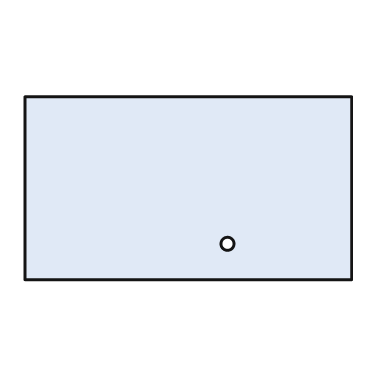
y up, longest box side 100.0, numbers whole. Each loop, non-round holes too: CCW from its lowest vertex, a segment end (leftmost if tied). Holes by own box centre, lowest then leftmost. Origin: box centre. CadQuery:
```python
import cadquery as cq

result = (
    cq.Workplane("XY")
    .moveTo(-50.0, -28.0)
    .lineTo(50.0, -28.0)
    .lineTo(50.0, 28.0)
    .lineTo(-50.0, 28.0)
    .close()
    .moveTo(12.0, -17.0)
    .circle(2.0)
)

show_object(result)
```